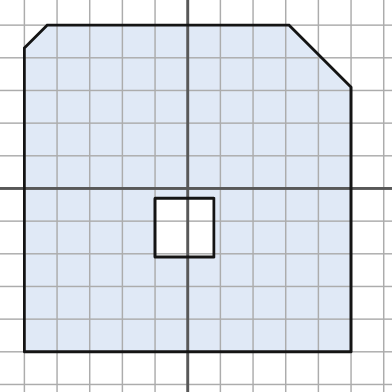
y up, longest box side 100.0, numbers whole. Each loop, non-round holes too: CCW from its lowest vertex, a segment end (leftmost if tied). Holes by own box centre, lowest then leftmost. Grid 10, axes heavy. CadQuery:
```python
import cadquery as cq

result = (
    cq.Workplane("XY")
    .moveTo(-50.0, -50.0)
    .lineTo(50.0, -50.0)
    .lineTo(50.0, 31.0)
    .lineTo(31.0, 50.0)
    .lineTo(-43.0, 50.0)
    .lineTo(-50.0, 43.0)
    .close()
    .moveTo(-10.0, -21.0)
    .lineTo(8.0, -21.0)
    .lineTo(8.0, -3.0)
    .lineTo(-10.0, -3.0)
    .close()
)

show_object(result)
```